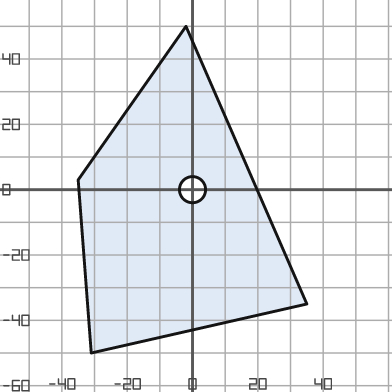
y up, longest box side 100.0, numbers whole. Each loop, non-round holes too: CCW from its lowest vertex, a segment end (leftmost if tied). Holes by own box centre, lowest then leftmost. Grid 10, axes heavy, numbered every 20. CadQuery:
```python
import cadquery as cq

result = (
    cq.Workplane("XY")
    .moveTo(-31.0, -50.0)
    .lineTo(35.0, -35.0)
    .lineTo(-2.0, 50.0)
    .lineTo(-35.0, 3.0)
    .close()
    .moveTo(0.0, 0.0)
    .circle(4.0)
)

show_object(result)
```